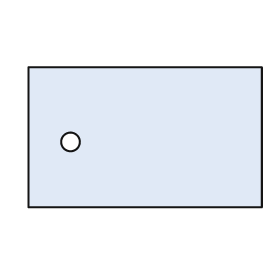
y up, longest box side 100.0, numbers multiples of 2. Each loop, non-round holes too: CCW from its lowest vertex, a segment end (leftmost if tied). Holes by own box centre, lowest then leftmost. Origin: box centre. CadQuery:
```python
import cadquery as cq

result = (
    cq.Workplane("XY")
    .moveTo(-50.0, -30.0)
    .lineTo(50.0, -30.0)
    .lineTo(50.0, 30.0)
    .lineTo(-50.0, 30.0)
    .close()
    .moveTo(-32.0, -2.0)
    .circle(4.0)
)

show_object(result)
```